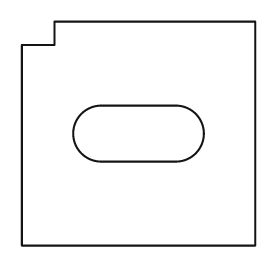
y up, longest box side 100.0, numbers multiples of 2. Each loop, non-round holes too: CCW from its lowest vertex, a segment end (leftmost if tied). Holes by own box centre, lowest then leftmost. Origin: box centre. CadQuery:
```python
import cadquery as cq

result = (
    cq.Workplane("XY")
    .moveTo(-50.0, -48.0)
    .lineTo(50.0, -48.0)
    .lineTo(50.0, 48.0)
    .lineTo(-36.0, 48.0)
    .lineTo(-36.0, 38.0)
    .lineTo(-50.0, 38.0)
    .close()
    .moveTo(-16.0, -12.0)
    .lineTo(16.0, -12.0)
    .threePointArc((28.0, 0.0), (16.0, 12.0))
    .lineTo(-16.0, 12.0)
    .threePointArc((-28.0, 0.0), (-16.0, -12.0))
    .close()
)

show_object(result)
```